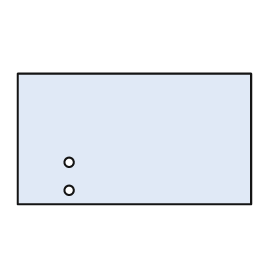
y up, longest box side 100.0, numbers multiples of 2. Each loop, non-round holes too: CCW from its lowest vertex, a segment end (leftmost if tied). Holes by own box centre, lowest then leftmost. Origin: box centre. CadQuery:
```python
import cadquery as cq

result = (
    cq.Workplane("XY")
    .moveTo(-50.0, -28.0)
    .lineTo(50.0, -28.0)
    .lineTo(50.0, 28.0)
    .lineTo(-50.0, 28.0)
    .close()
    .moveTo(-28.0, -22.0)
    .circle(2.0)
    .moveTo(-28.0, -10.0)
    .circle(2.0)
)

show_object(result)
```